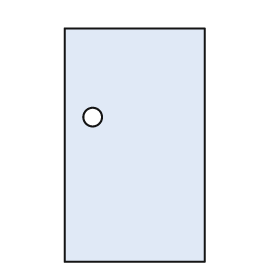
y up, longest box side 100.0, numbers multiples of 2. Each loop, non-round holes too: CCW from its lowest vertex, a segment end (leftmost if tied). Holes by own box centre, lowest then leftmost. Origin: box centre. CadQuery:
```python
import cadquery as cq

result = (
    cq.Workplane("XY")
    .moveTo(-30.0, -50.0)
    .lineTo(30.0, -50.0)
    .lineTo(30.0, 50.0)
    .lineTo(-30.0, 50.0)
    .close()
    .moveTo(-18.0, 12.0)
    .circle(4.0)
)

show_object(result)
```